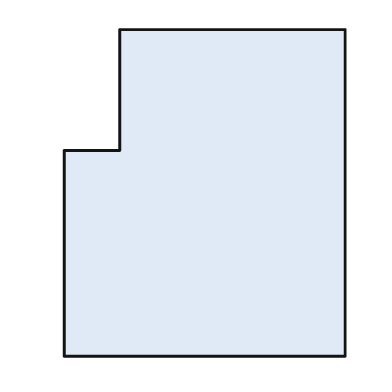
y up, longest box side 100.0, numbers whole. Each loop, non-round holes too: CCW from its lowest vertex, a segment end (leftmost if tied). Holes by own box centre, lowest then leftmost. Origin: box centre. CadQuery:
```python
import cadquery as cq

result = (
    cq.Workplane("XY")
    .moveTo(-43.0, -50.0)
    .lineTo(43.0, -50.0)
    .lineTo(43.0, 50.0)
    .lineTo(-26.0, 50.0)
    .lineTo(-26.0, 13.0)
    .lineTo(-43.0, 13.0)
    .close()
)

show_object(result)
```